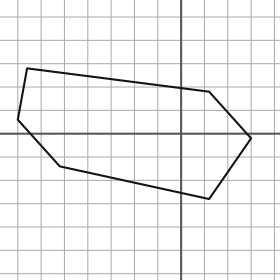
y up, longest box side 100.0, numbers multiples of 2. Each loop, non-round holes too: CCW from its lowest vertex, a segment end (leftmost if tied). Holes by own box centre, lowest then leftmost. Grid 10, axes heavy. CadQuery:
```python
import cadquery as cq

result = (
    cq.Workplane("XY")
    .moveTo(12.0, -28.0)
    .lineTo(30.0, -2.0)
    .lineTo(12.0, 18.0)
    .lineTo(-66.0, 28.0)
    .lineTo(-70.0, 6.0)
    .lineTo(-52.0, -14.0)
    .close()
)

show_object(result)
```